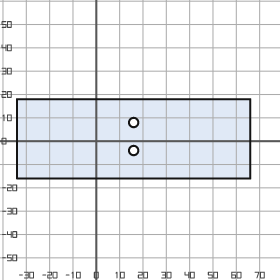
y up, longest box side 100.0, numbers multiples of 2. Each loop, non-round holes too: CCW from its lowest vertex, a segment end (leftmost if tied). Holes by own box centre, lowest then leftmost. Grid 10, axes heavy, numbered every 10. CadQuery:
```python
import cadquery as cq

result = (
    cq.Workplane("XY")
    .moveTo(-34.0, -16.0)
    .lineTo(66.0, -16.0)
    .lineTo(66.0, 18.0)
    .lineTo(-34.0, 18.0)
    .close()
    .moveTo(16.0, -4.0)
    .circle(2.0)
    .moveTo(16.0, 8.0)
    .circle(2.0)
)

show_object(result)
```